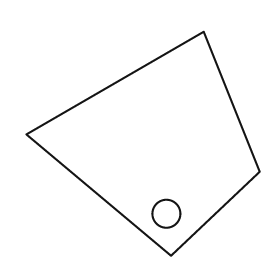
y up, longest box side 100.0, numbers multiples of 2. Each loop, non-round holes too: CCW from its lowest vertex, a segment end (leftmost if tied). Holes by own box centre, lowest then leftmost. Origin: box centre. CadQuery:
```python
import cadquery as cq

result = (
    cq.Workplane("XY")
    .moveTo(12.0, -48.0)
    .lineTo(50.0, -12.0)
    .lineTo(26.0, 48.0)
    .lineTo(-50.0, 4.0)
    .close()
    .moveTo(10.0, -30.0)
    .circle(6.0)
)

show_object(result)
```